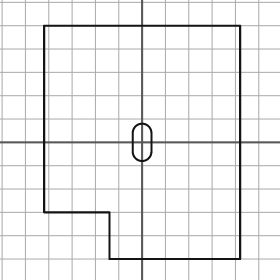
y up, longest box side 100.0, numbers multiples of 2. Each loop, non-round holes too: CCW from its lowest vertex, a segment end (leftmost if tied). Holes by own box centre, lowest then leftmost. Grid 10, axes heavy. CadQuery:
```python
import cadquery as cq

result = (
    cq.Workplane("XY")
    .moveTo(-14.0, -50.0)
    .lineTo(42.0, -50.0)
    .lineTo(42.0, 50.0)
    .lineTo(-42.0, 50.0)
    .lineTo(-42.0, -30.0)
    .lineTo(-14.0, -30.0)
    .close()
    .moveTo(-4.0, -4.0)
    .threePointArc((0.0, -8.0), (4.0, -4.0))
    .lineTo(4.0, 4.0)
    .threePointArc((0.0, 8.0), (-4.0, 4.0))
    .close()
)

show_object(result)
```